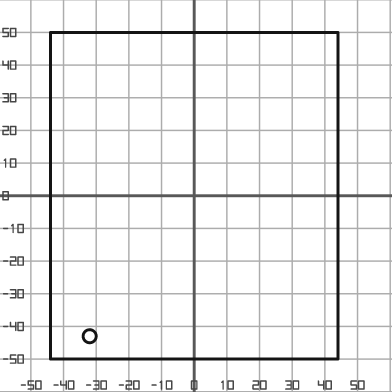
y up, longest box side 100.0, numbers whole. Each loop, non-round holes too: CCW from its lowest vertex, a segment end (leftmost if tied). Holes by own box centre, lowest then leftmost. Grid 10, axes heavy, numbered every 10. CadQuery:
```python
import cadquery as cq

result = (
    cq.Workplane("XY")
    .moveTo(-44.0, -50.0)
    .lineTo(44.0, -50.0)
    .lineTo(44.0, 50.0)
    .lineTo(-44.0, 50.0)
    .close()
    .moveTo(-32.0, -43.0)
    .circle(2.0)
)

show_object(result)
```